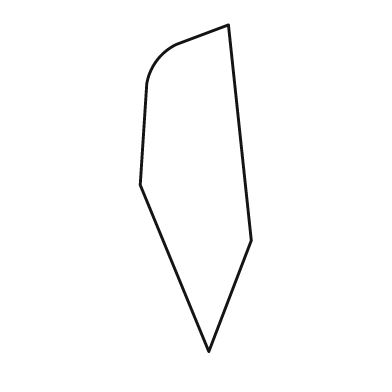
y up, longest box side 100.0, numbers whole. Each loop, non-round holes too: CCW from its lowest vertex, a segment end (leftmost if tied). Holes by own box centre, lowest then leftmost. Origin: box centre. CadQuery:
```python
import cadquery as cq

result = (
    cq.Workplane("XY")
    .moveTo(4.0, -50.0)
    .lineTo(17.0, -16.0)
    .lineTo(10.0, 50.0)
    .lineTo(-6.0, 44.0)
    .threePointArc((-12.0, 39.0), (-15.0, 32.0))
    .lineTo(-17.0, 1.0)
    .close()
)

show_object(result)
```